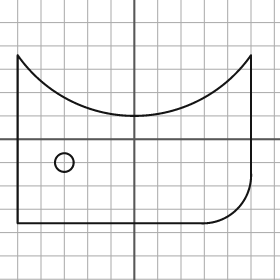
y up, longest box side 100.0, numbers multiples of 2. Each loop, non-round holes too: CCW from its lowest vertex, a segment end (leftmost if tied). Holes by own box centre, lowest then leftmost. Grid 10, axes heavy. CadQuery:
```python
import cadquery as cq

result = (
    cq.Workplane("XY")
    .moveTo(-50.0, -36.0)
    .lineTo(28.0, -36.0)
    .threePointArc((44.0, -30.0), (50.0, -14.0))
    .lineTo(50.0, 36.0)
    .threePointArc((0.0, 10.0), (-50.0, 36.0))
    .close()
    .moveTo(-30.0, -10.0)
    .circle(4.0)
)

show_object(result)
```